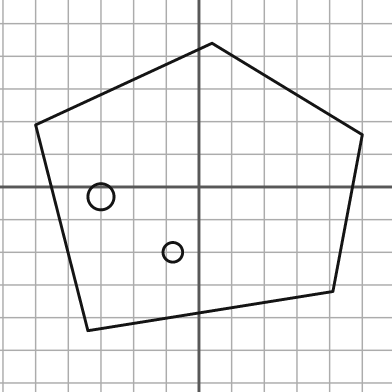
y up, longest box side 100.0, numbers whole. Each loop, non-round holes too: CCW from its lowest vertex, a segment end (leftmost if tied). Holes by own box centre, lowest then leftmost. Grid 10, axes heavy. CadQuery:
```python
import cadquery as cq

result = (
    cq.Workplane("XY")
    .moveTo(-34.0, -44.0)
    .lineTo(41.0, -32.0)
    .lineTo(50.0, 16.0)
    .lineTo(4.0, 44.0)
    .lineTo(-50.0, 19.0)
    .close()
    .moveTo(-8.0, -20.0)
    .circle(3.0)
    .moveTo(-30.0, -3.0)
    .circle(4.0)
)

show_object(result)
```